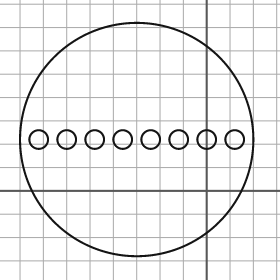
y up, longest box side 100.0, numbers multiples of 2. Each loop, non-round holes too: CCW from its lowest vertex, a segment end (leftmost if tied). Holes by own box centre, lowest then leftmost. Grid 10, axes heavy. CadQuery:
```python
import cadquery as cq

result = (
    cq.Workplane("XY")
    .moveTo(-30.0, 22.0)
    .circle(50.0)
    .moveTo(-72.0, 22.0)
    .circle(4.0)
    .moveTo(-60.0, 22.0)
    .circle(4.0)
    .moveTo(-48.0, 22.0)
    .circle(4.0)
    .moveTo(-36.0, 22.0)
    .circle(4.0)
    .moveTo(-24.0, 22.0)
    .circle(4.0)
    .moveTo(-12.0, 22.0)
    .circle(4.0)
    .moveTo(0.0, 22.0)
    .circle(4.0)
    .moveTo(12.0, 22.0)
    .circle(4.0)
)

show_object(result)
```